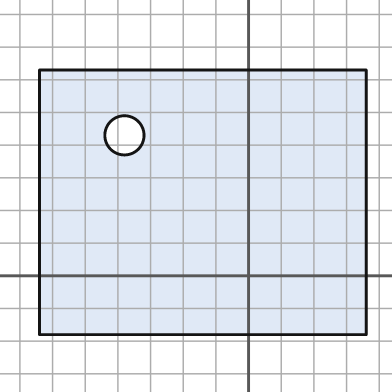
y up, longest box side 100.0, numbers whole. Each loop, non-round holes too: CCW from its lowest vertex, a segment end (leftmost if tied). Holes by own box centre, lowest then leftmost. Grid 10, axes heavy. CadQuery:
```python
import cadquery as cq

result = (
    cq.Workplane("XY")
    .moveTo(-64.0, -18.0)
    .lineTo(36.0, -18.0)
    .lineTo(36.0, 63.0)
    .lineTo(-64.0, 63.0)
    .close()
    .moveTo(-38.0, 43.0)
    .circle(6.0)
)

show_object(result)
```